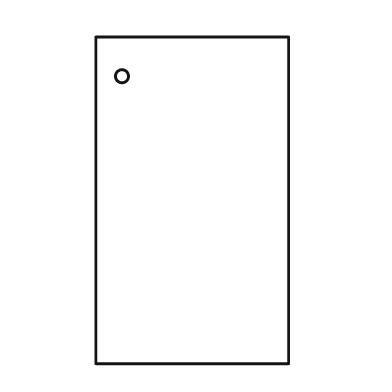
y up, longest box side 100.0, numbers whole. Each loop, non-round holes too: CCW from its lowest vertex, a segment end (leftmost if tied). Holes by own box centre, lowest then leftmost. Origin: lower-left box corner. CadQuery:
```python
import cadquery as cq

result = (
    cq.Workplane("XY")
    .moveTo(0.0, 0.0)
    .lineTo(59.0, 0.0)
    .lineTo(59.0, 100.0)
    .lineTo(0.0, 100.0)
    .close()
    .moveTo(8.0, 88.0)
    .circle(2.0)
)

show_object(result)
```